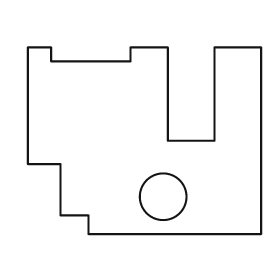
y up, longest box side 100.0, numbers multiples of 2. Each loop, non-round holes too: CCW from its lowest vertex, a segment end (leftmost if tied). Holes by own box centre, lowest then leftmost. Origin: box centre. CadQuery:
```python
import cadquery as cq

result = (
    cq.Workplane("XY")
    .moveTo(-24.0, -40.0)
    .lineTo(50.0, -40.0)
    .lineTo(50.0, 40.0)
    .lineTo(30.0, 40.0)
    .lineTo(30.0, 0.0)
    .lineTo(10.0, 0.0)
    .lineTo(10.0, 40.0)
    .lineTo(-6.0, 40.0)
    .lineTo(-6.0, 34.0)
    .lineTo(-40.0, 34.0)
    .lineTo(-40.0, 40.0)
    .lineTo(-50.0, 40.0)
    .lineTo(-50.0, -10.0)
    .lineTo(-36.0, -10.0)
    .lineTo(-36.0, -32.0)
    .lineTo(-24.0, -32.0)
    .close()
    .moveTo(8.0, -24.0)
    .circle(10.0)
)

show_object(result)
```